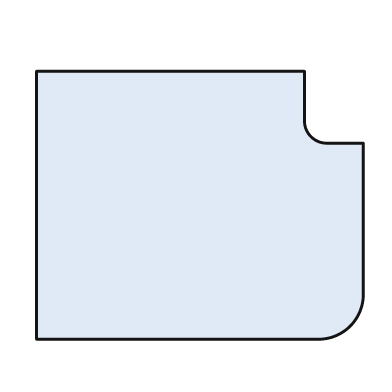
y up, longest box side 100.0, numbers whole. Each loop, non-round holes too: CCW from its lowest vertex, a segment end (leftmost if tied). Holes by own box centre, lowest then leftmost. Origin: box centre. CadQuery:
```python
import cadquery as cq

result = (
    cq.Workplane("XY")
    .moveTo(-50.0, -41.0)
    .lineTo(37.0, -41.0)
    .threePointArc((46.0, -37.0), (50.0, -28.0))
    .lineTo(50.0, 19.0)
    .lineTo(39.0, 19.0)
    .threePointArc((34.0, 21.0), (32.0, 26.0))
    .lineTo(32.0, 41.0)
    .lineTo(-50.0, 41.0)
    .close()
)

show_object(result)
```